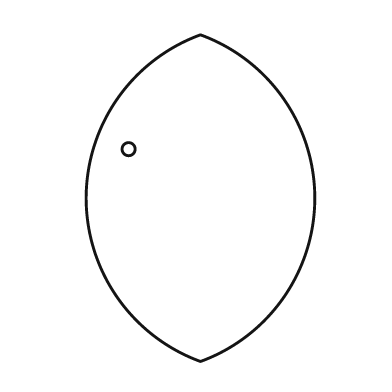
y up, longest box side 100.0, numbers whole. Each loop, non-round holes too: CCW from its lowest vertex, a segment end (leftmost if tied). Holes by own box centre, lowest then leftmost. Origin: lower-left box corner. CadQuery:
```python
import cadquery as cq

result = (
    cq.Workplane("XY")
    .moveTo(35.0, 0.0)
    .threePointArc((70.0, 50.0), (35.0, 100.0))
    .threePointArc((0.0, 50.0), (35.0, 0.0))
    .close()
    .moveTo(13.0, 65.0)
    .circle(2.0)
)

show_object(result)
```